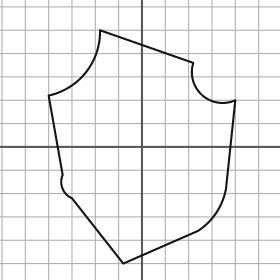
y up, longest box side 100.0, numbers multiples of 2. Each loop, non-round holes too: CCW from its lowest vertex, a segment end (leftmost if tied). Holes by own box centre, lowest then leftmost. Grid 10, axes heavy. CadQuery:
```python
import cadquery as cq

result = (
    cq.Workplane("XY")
    .moveTo(-8.0, -50.0)
    .lineTo(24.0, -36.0)
    .threePointArc((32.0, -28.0), (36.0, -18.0))
    .lineTo(40.0, 20.0)
    .threePointArc((26.0, 22.0), (22.0, 36.0))
    .lineTo(-18.0, 50.0)
    .threePointArc((-24.0, 32.0), (-40.0, 22.0))
    .lineTo(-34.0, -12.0)
    .threePointArc((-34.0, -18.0), (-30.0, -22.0))
    .close()
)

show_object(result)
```